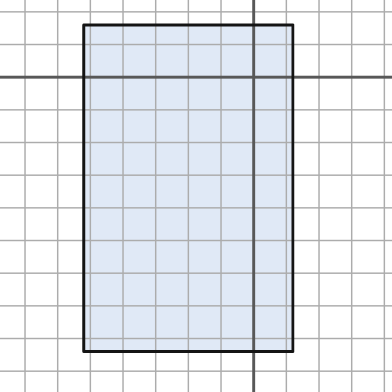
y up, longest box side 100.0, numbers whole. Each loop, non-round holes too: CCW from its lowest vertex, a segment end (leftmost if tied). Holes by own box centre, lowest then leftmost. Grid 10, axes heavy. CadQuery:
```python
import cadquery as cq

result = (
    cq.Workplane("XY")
    .moveTo(-52.0, -84.0)
    .lineTo(12.0, -84.0)
    .lineTo(12.0, 16.0)
    .lineTo(-52.0, 16.0)
    .close()
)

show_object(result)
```